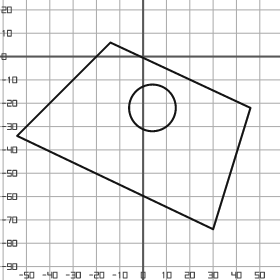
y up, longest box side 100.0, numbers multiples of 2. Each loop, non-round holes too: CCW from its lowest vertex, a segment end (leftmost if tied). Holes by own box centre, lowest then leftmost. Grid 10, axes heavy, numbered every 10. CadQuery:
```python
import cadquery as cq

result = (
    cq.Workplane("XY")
    .moveTo(30.0, -74.0)
    .lineTo(46.0, -22.0)
    .lineTo(-14.0, 6.0)
    .lineTo(-54.0, -34.0)
    .close()
    .moveTo(4.0, -22.0)
    .circle(10.0)
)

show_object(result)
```